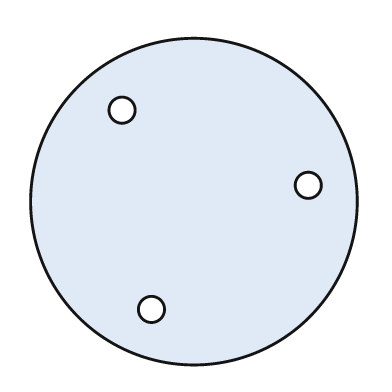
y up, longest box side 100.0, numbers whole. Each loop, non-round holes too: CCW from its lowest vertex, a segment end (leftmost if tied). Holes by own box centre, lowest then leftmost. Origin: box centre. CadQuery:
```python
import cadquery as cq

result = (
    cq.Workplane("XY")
    .moveTo(0.0, 0.0)
    .circle(50.0)
    .moveTo(-13.0, -33.0)
    .circle(4.0)
    .moveTo(35.0, 5.0)
    .circle(4.0)
    .moveTo(-22.0, 28.0)
    .circle(4.0)
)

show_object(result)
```